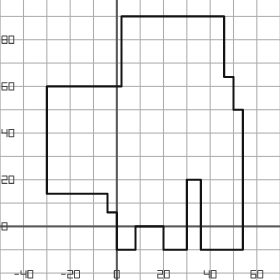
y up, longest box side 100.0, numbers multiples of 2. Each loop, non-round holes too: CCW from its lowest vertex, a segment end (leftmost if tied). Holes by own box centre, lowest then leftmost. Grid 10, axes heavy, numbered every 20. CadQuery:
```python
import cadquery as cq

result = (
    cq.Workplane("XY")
    .moveTo(0.0, -10.0)
    .lineTo(8.0, -10.0)
    .lineTo(8.0, 0.0)
    .lineTo(20.0, 0.0)
    .lineTo(20.0, -10.0)
    .lineTo(30.0, -10.0)
    .lineTo(30.0, 20.0)
    .lineTo(36.0, 20.0)
    .lineTo(36.0, -10.0)
    .lineTo(54.0, -10.0)
    .lineTo(54.0, 50.0)
    .lineTo(50.0, 50.0)
    .lineTo(50.0, 64.0)
    .lineTo(46.0, 64.0)
    .lineTo(46.0, 90.0)
    .lineTo(2.0, 90.0)
    .lineTo(2.0, 60.0)
    .lineTo(-30.0, 60.0)
    .lineTo(-30.0, 14.0)
    .lineTo(-4.0, 14.0)
    .lineTo(-4.0, 6.0)
    .lineTo(0.0, 6.0)
    .close()
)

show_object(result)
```